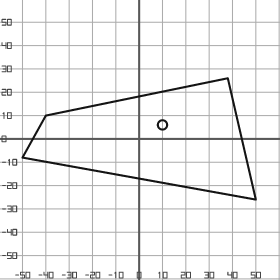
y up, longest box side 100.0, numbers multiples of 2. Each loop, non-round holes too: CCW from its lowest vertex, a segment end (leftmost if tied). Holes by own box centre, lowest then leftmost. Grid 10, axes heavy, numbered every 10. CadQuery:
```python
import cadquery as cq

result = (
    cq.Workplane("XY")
    .moveTo(50.0, -26.0)
    .lineTo(38.0, 26.0)
    .lineTo(-40.0, 10.0)
    .lineTo(-50.0, -8.0)
    .close()
    .moveTo(10.0, 6.0)
    .circle(2.0)
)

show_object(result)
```